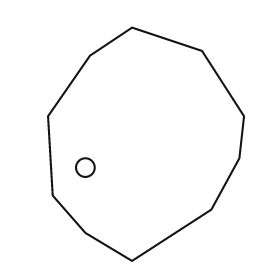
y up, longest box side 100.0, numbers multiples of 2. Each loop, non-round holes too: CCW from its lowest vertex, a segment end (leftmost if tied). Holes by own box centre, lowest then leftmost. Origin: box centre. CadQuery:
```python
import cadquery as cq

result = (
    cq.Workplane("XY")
    .moveTo(-6.0, -50.0)
    .lineTo(28.0, -28.0)
    .lineTo(40.0, -6.0)
    .lineTo(42.0, 12.0)
    .lineTo(24.0, 40.0)
    .lineTo(-6.0, 50.0)
    .lineTo(-24.0, 38.0)
    .lineTo(-42.0, 12.0)
    .lineTo(-40.0, -22.0)
    .lineTo(-26.0, -38.0)
    .close()
    .moveTo(-26.0, -10.0)
    .circle(4.0)
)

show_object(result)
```